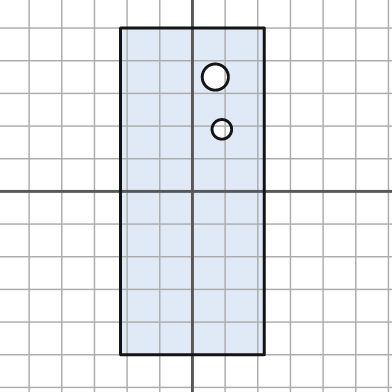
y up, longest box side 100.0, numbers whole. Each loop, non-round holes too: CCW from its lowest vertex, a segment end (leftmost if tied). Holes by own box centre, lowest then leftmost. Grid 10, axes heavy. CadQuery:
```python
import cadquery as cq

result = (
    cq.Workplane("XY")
    .moveTo(-22.0, -50.0)
    .lineTo(22.0, -50.0)
    .lineTo(22.0, 50.0)
    .lineTo(-22.0, 50.0)
    .close()
    .moveTo(9.0, 19.0)
    .circle(3.0)
    .moveTo(7.0, 35.0)
    .circle(4.0)
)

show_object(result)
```